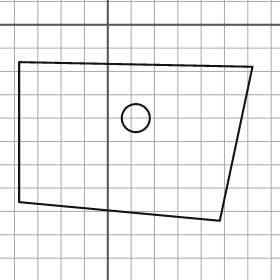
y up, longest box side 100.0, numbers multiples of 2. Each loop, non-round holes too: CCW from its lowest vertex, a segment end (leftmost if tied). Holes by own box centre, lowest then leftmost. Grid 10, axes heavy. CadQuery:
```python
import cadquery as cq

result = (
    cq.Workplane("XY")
    .moveTo(48.0, -84.0)
    .lineTo(62.0, -18.0)
    .lineTo(-38.0, -16.0)
    .lineTo(-38.0, -76.0)
    .close()
    .moveTo(12.0, -40.0)
    .circle(6.0)
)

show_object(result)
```